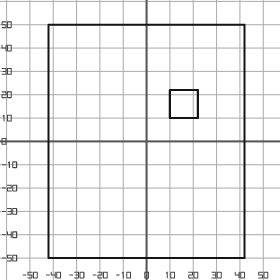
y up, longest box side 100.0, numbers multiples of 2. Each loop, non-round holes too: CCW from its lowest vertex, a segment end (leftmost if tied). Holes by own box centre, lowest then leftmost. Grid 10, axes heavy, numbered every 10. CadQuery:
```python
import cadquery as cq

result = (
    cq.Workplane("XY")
    .moveTo(-42.0, -50.0)
    .lineTo(42.0, -50.0)
    .lineTo(42.0, 50.0)
    .lineTo(-42.0, 50.0)
    .close()
    .moveTo(10.0, 10.0)
    .lineTo(22.0, 10.0)
    .lineTo(22.0, 22.0)
    .lineTo(10.0, 22.0)
    .close()
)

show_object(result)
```